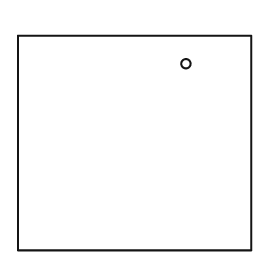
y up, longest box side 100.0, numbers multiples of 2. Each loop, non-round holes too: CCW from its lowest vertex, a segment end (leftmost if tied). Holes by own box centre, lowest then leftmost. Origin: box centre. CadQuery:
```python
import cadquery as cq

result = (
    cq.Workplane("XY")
    .moveTo(-50.0, -46.0)
    .lineTo(50.0, -46.0)
    .lineTo(50.0, 46.0)
    .lineTo(-50.0, 46.0)
    .close()
    .moveTo(22.0, 34.0)
    .circle(2.0)
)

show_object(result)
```